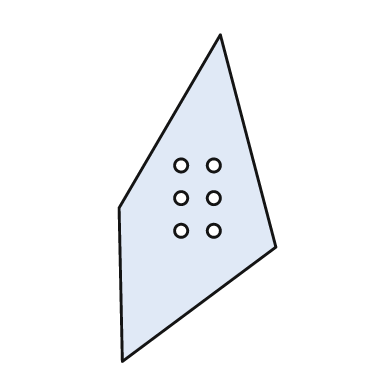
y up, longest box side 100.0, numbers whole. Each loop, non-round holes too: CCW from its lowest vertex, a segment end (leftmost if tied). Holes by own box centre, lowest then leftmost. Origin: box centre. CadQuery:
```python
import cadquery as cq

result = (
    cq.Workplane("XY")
    .moveTo(-23.0, -50.0)
    .lineTo(24.0, -15.0)
    .lineTo(7.0, 50.0)
    .lineTo(-24.0, -3.0)
    .close()
    .moveTo(-5.0, -10.0)
    .circle(2.0)
    .moveTo(5.0, -10.0)
    .circle(2.0)
    .moveTo(-5.0, 0.0)
    .circle(2.0)
    .moveTo(5.0, 0.0)
    .circle(2.0)
    .moveTo(-5.0, 10.0)
    .circle(2.0)
    .moveTo(5.0, 10.0)
    .circle(2.0)
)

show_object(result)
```